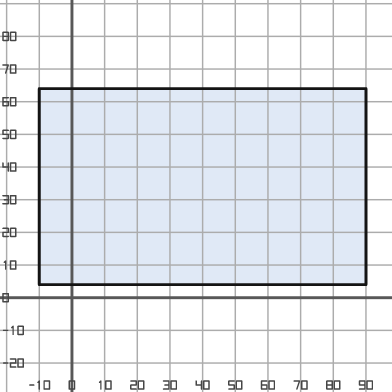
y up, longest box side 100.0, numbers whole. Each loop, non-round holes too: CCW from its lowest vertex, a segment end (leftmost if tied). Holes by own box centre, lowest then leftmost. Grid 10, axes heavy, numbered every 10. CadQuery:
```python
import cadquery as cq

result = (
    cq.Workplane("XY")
    .moveTo(-10.0, 4.0)
    .lineTo(90.0, 4.0)
    .lineTo(90.0, 64.0)
    .lineTo(-10.0, 64.0)
    .close()
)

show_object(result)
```